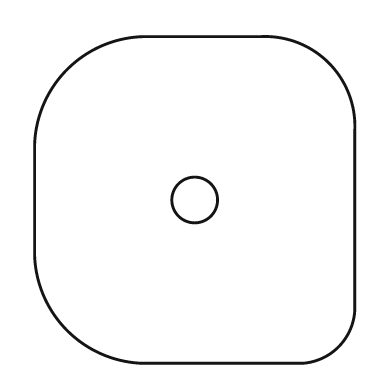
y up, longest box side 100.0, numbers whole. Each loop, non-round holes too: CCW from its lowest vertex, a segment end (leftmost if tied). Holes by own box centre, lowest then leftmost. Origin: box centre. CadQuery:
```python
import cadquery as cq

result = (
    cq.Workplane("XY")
    .moveTo(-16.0, -50.0)
    .lineTo(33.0, -50.0)
    .threePointArc((44.0, -45.0), (49.0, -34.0))
    .lineTo(49.0, 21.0)
    .threePointArc((41.0, 42.0), (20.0, 50.0))
    .lineTo(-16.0, 50.0)
    .threePointArc((-39.0, 40.0), (-49.0, 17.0))
    .lineTo(-49.0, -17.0)
    .threePointArc((-39.0, -40.0), (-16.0, -50.0))
    .close()
    .moveTo(0.0, 0.0)
    .circle(7.0)
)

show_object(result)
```